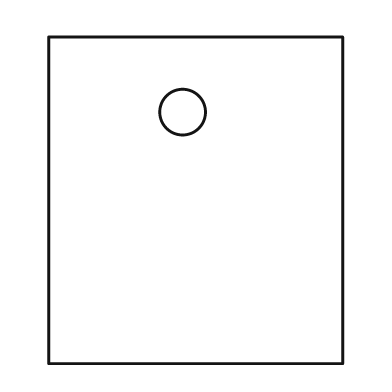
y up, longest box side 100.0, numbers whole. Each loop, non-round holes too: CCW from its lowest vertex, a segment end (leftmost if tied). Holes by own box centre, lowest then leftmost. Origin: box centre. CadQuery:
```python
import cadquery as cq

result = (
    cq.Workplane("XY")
    .moveTo(-45.0, -50.0)
    .lineTo(45.0, -50.0)
    .lineTo(45.0, 50.0)
    .lineTo(-45.0, 50.0)
    .close()
    .moveTo(-4.0, 27.0)
    .circle(7.0)
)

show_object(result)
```